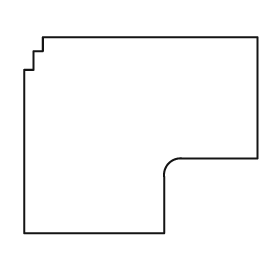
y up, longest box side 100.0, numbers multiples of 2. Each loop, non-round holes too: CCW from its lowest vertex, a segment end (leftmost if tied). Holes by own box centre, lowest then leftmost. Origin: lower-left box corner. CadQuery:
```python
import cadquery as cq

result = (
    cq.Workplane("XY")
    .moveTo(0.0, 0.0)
    .lineTo(60.0, 0.0)
    .lineTo(60.0, 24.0)
    .threePointArc((62.0, 30.0), (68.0, 32.0))
    .lineTo(100.0, 32.0)
    .lineTo(100.0, 84.0)
    .lineTo(8.0, 84.0)
    .lineTo(8.0, 78.0)
    .lineTo(4.0, 78.0)
    .lineTo(4.0, 70.0)
    .lineTo(0.0, 70.0)
    .close()
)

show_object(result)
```